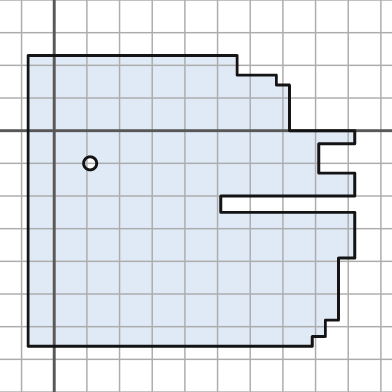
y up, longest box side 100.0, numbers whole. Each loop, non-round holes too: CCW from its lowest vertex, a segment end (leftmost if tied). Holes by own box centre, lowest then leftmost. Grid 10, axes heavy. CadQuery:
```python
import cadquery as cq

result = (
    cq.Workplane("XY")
    .moveTo(-8.0, -66.0)
    .lineTo(79.0, -66.0)
    .lineTo(79.0, -63.0)
    .lineTo(83.0, -63.0)
    .lineTo(83.0, -58.0)
    .lineTo(87.0, -58.0)
    .lineTo(87.0, -39.0)
    .lineTo(92.0, -39.0)
    .lineTo(92.0, -25.0)
    .lineTo(51.0, -25.0)
    .lineTo(51.0, -20.0)
    .lineTo(92.0, -20.0)
    .lineTo(92.0, -13.0)
    .lineTo(81.0, -13.0)
    .lineTo(81.0, -4.0)
    .lineTo(92.0, -4.0)
    .lineTo(92.0, 0.0)
    .lineTo(72.0, 0.0)
    .lineTo(72.0, 14.0)
    .lineTo(68.0, 14.0)
    .lineTo(68.0, 17.0)
    .lineTo(56.0, 17.0)
    .lineTo(56.0, 23.0)
    .lineTo(-8.0, 23.0)
    .close()
    .moveTo(11.0, -10.0)
    .circle(2.0)
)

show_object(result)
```